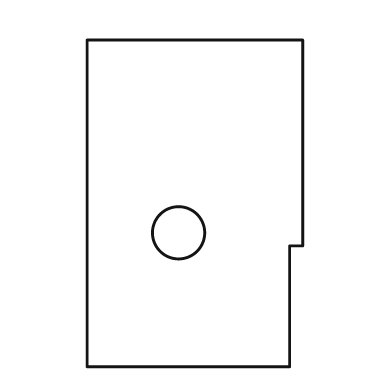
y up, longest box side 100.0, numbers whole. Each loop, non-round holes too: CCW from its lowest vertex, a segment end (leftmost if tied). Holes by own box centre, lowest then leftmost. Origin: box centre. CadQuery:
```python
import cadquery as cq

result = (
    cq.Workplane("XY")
    .moveTo(-33.0, -50.0)
    .lineTo(29.0, -50.0)
    .lineTo(29.0, -13.0)
    .lineTo(33.0, -13.0)
    .lineTo(33.0, 50.0)
    .lineTo(-33.0, 50.0)
    .close()
    .moveTo(-5.0, -9.0)
    .circle(8.0)
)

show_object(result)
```